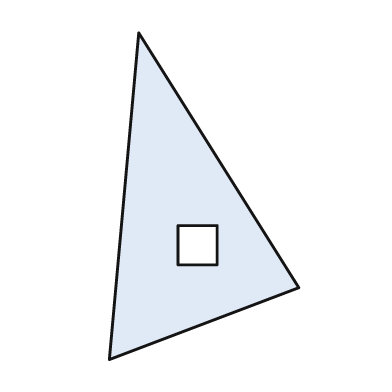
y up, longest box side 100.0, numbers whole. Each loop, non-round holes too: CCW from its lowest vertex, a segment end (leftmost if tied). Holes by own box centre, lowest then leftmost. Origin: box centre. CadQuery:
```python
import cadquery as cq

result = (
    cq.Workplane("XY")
    .moveTo(-29.0, -50.0)
    .lineTo(29.0, -28.0)
    .lineTo(-20.0, 50.0)
    .close()
    .moveTo(-8.0, -21.0)
    .lineTo(4.0, -21.0)
    .lineTo(4.0, -9.0)
    .lineTo(-8.0, -9.0)
    .close()
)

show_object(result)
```